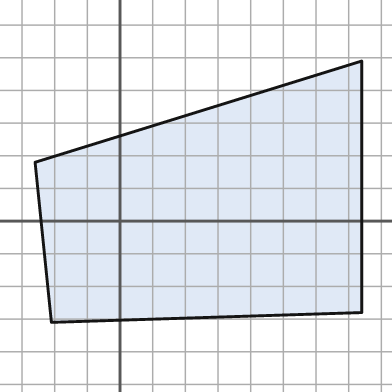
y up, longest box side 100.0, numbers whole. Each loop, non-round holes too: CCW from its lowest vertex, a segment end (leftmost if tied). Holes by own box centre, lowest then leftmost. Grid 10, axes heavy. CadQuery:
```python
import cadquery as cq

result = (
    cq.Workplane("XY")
    .moveTo(-21.0, -31.0)
    .lineTo(74.0, -28.0)
    .lineTo(74.0, 49.0)
    .lineTo(-26.0, 18.0)
    .close()
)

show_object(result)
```